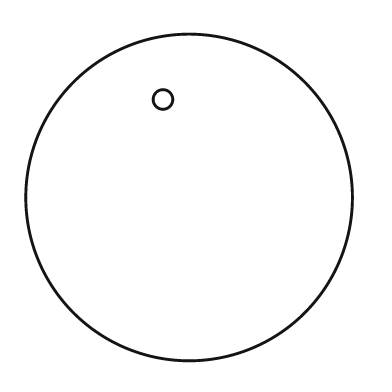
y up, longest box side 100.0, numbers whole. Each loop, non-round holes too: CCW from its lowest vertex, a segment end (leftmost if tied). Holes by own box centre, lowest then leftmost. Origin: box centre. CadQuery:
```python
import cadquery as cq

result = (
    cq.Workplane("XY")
    .moveTo(0.0, 0.0)
    .circle(50.0)
    .moveTo(-8.0, 30.0)
    .circle(3.0)
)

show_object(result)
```